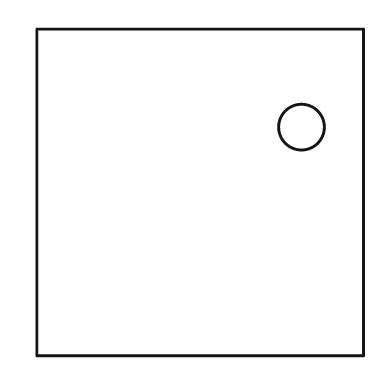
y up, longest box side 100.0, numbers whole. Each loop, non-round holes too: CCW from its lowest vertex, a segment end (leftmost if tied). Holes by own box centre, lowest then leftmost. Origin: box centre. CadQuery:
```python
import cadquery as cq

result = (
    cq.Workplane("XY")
    .moveTo(-50.0, -50.0)
    .lineTo(50.0, -50.0)
    .lineTo(50.0, 50.0)
    .lineTo(-50.0, 50.0)
    .close()
    .moveTo(31.0, 20.0)
    .circle(7.0)
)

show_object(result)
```